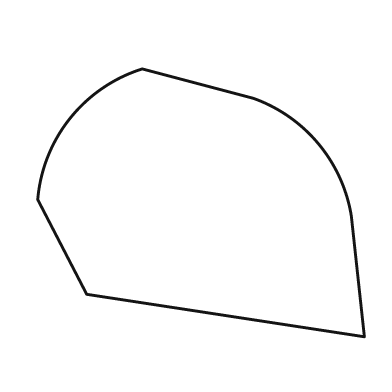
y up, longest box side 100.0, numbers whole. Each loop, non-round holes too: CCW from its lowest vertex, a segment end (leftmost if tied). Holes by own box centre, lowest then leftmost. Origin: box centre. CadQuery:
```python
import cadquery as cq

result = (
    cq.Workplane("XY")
    .moveTo(50.0, -41.0)
    .lineTo(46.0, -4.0)
    .threePointArc((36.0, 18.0), (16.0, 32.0))
    .lineTo(-18.0, 41.0)
    .threePointArc((-40.0, 26.0), (-50.0, 1.0))
    .lineTo(-35.0, -28.0)
    .close()
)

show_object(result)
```